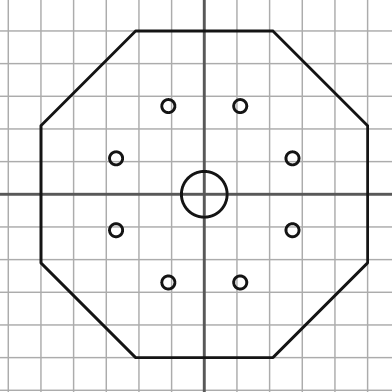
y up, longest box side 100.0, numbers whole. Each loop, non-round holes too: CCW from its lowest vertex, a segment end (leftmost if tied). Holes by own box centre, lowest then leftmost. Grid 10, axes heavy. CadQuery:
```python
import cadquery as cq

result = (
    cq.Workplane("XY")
    .moveTo(-21.0, -50.0)
    .lineTo(21.0, -50.0)
    .lineTo(50.0, -21.0)
    .lineTo(50.0, 21.0)
    .lineTo(21.0, 50.0)
    .lineTo(-21.0, 50.0)
    .lineTo(-50.0, 21.0)
    .lineTo(-50.0, -21.0)
    .close()
    .moveTo(-11.0, -27.0)
    .circle(2.0)
    .moveTo(11.0, -27.0)
    .circle(2.0)
    .moveTo(-27.0, -11.0)
    .circle(2.0)
    .moveTo(27.0, -11.0)
    .circle(2.0)
    .moveTo(0.0, 0.0)
    .circle(7.0)
    .moveTo(-27.0, 11.0)
    .circle(2.0)
    .moveTo(27.0, 11.0)
    .circle(2.0)
    .moveTo(-11.0, 27.0)
    .circle(2.0)
    .moveTo(11.0, 27.0)
    .circle(2.0)
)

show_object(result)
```